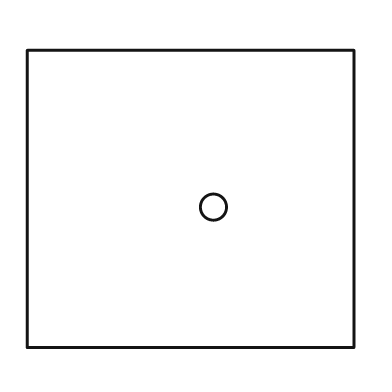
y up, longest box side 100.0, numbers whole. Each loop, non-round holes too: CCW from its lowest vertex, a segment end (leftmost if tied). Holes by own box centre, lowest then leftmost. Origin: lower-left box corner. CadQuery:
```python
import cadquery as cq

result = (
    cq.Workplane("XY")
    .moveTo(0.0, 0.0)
    .lineTo(100.0, 0.0)
    .lineTo(100.0, 91.0)
    .lineTo(0.0, 91.0)
    .close()
    .moveTo(57.0, 43.0)
    .circle(4.0)
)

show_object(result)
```